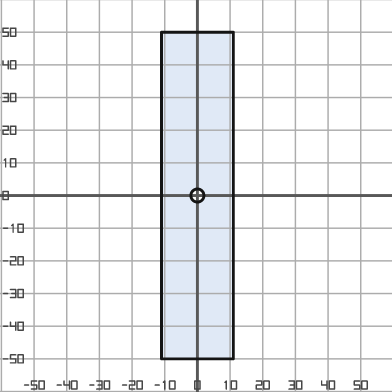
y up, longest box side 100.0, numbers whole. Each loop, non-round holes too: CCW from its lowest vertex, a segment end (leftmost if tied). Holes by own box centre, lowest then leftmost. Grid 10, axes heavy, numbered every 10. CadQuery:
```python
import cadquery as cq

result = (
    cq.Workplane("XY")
    .moveTo(-11.0, -50.0)
    .lineTo(11.0, -50.0)
    .lineTo(11.0, 50.0)
    .lineTo(-11.0, 50.0)
    .close()
    .moveTo(0.0, 0.0)
    .circle(2.0)
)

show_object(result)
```